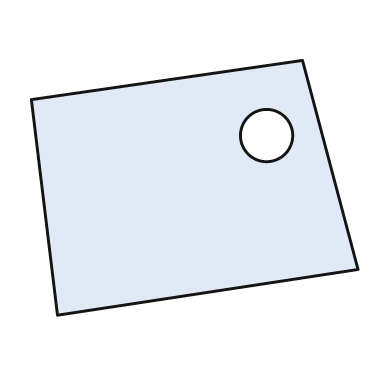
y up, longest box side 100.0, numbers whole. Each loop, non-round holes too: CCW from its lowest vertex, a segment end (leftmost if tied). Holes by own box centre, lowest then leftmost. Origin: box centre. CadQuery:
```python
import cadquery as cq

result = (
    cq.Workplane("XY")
    .moveTo(-42.0, -39.0)
    .lineTo(50.0, -25.0)
    .lineTo(33.0, 39.0)
    .lineTo(-50.0, 27.0)
    .close()
    .moveTo(22.0, 16.0)
    .circle(8.0)
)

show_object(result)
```